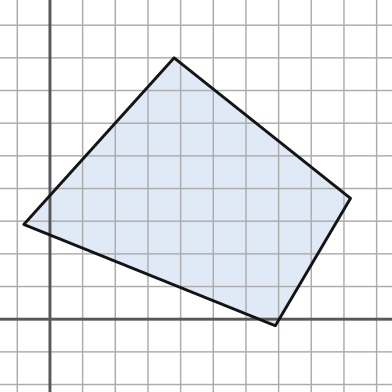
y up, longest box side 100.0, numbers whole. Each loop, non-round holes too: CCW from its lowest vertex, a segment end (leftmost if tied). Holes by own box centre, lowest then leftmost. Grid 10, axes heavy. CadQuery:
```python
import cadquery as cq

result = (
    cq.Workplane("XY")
    .moveTo(69.0, -2.0)
    .lineTo(92.0, 37.0)
    .lineTo(38.0, 80.0)
    .lineTo(-8.0, 29.0)
    .close()
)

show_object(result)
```